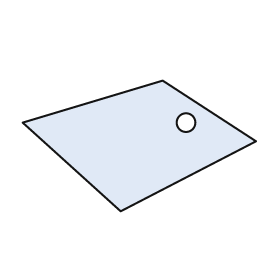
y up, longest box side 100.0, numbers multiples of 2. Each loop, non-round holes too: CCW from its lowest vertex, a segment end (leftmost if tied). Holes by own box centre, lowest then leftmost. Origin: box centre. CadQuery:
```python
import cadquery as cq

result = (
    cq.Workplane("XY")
    .moveTo(-8.0, -28.0)
    .lineTo(50.0, 2.0)
    .lineTo(10.0, 28.0)
    .lineTo(-50.0, 10.0)
    .close()
    .moveTo(20.0, 10.0)
    .circle(4.0)
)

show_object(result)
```